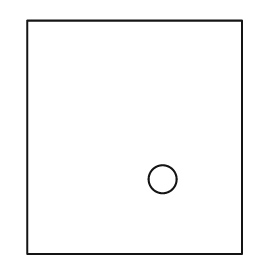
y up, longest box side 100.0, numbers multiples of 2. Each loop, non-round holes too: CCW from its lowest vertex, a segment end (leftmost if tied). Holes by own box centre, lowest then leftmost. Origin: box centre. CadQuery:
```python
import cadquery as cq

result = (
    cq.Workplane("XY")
    .moveTo(-46.0, -50.0)
    .lineTo(46.0, -50.0)
    .lineTo(46.0, 50.0)
    .lineTo(-46.0, 50.0)
    .close()
    .moveTo(12.0, -18.0)
    .circle(6.0)
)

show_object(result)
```